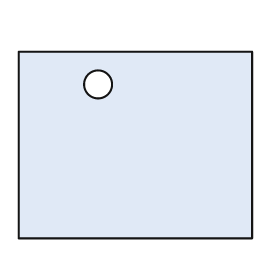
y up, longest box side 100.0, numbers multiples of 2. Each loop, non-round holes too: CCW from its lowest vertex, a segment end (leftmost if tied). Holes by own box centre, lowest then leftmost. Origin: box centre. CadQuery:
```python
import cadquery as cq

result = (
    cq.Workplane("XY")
    .moveTo(-50.0, -40.0)
    .lineTo(50.0, -40.0)
    .lineTo(50.0, 40.0)
    .lineTo(-50.0, 40.0)
    .close()
    .moveTo(-16.0, 26.0)
    .circle(6.0)
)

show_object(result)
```